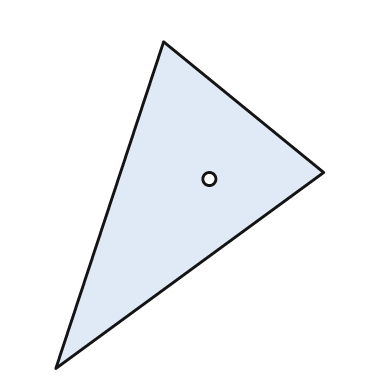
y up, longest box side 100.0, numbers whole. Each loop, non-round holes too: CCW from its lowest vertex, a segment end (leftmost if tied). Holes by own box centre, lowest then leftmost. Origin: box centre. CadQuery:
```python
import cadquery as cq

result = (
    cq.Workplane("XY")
    .moveTo(-41.0, -50.0)
    .lineTo(41.0, 10.0)
    .lineTo(-8.0, 50.0)
    .close()
    .moveTo(6.0, 8.0)
    .circle(2.0)
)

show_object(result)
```